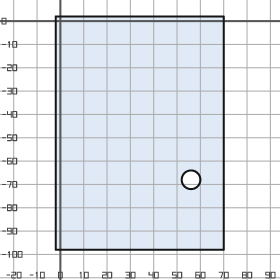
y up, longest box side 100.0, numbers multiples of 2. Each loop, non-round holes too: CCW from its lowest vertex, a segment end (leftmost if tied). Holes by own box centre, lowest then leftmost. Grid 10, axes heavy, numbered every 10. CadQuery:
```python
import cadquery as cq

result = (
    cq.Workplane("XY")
    .moveTo(-2.0, -98.0)
    .lineTo(70.0, -98.0)
    .lineTo(70.0, 2.0)
    .lineTo(-2.0, 2.0)
    .close()
    .moveTo(56.0, -68.0)
    .circle(4.0)
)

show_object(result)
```